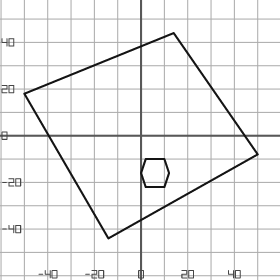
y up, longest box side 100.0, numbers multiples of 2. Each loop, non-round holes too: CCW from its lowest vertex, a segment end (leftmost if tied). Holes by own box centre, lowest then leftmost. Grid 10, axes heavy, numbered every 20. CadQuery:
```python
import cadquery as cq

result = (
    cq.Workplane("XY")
    .moveTo(-14.0, -44.0)
    .lineTo(50.0, -8.0)
    .lineTo(14.0, 44.0)
    .lineTo(-50.0, 18.0)
    .close()
    .moveTo(2.0, -22.0)
    .lineTo(10.0, -22.0)
    .lineTo(12.0, -16.0)
    .lineTo(10.0, -10.0)
    .lineTo(2.0, -10.0)
    .lineTo(0.0, -16.0)
    .close()
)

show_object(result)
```